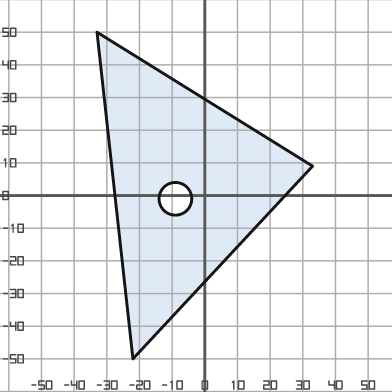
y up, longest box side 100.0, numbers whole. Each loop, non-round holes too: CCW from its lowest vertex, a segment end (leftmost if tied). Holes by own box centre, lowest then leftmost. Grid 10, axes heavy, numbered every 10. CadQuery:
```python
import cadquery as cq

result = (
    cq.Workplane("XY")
    .moveTo(-22.0, -50.0)
    .lineTo(33.0, 9.0)
    .lineTo(-33.0, 50.0)
    .close()
    .moveTo(-9.0, -1.0)
    .circle(5.0)
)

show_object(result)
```